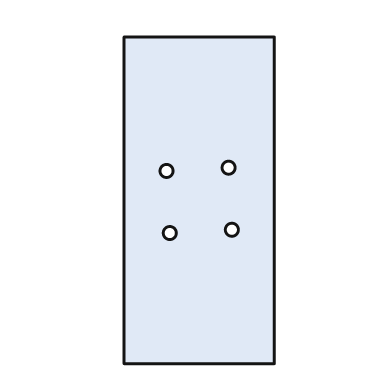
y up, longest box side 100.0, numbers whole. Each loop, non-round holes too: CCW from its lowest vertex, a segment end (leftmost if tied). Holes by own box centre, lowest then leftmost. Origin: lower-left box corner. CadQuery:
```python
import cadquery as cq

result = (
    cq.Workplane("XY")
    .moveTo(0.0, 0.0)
    .lineTo(46.0, 0.0)
    .lineTo(46.0, 100.0)
    .lineTo(0.0, 100.0)
    .close()
    .moveTo(14.0, 40.0)
    .circle(2.0)
    .moveTo(33.0, 41.0)
    .circle(2.0)
    .moveTo(13.0, 59.0)
    .circle(2.0)
    .moveTo(32.0, 60.0)
    .circle(2.0)
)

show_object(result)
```